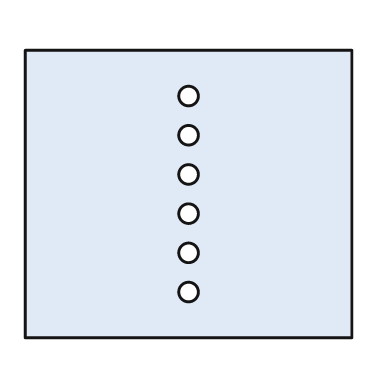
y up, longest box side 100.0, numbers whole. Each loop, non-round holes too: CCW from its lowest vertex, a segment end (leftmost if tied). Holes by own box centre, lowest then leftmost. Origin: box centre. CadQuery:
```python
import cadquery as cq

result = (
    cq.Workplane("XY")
    .moveTo(-50.0, -44.0)
    .lineTo(50.0, -44.0)
    .lineTo(50.0, 44.0)
    .lineTo(-50.0, 44.0)
    .close()
    .moveTo(0.0, -30.0)
    .circle(3.0)
    .moveTo(0.0, -18.0)
    .circle(3.0)
    .moveTo(0.0, -6.0)
    .circle(3.0)
    .moveTo(0.0, 6.0)
    .circle(3.0)
    .moveTo(0.0, 18.0)
    .circle(3.0)
    .moveTo(0.0, 30.0)
    .circle(3.0)
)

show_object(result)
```